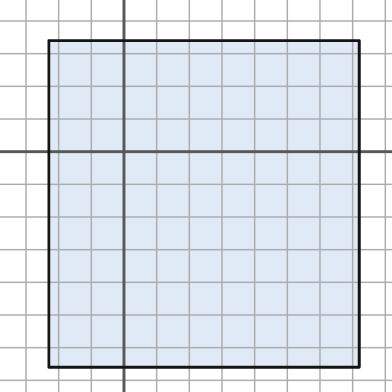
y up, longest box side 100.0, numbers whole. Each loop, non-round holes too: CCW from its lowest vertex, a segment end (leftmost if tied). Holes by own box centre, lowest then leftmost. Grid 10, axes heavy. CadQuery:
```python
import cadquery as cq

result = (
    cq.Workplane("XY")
    .moveTo(-23.0, -66.0)
    .lineTo(72.0, -66.0)
    .lineTo(72.0, 34.0)
    .lineTo(-23.0, 34.0)
    .close()
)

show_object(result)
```